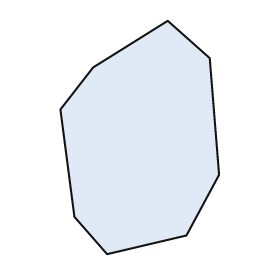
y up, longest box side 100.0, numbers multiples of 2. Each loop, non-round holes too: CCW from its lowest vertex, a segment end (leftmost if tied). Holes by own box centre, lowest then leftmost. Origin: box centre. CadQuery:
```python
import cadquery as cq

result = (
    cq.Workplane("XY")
    .moveTo(-14.0, -50.0)
    .lineTo(20.0, -42.0)
    .lineTo(34.0, -16.0)
    .lineTo(30.0, 34.0)
    .lineTo(12.0, 50.0)
    .lineTo(-20.0, 30.0)
    .lineTo(-34.0, 12.0)
    .lineTo(-28.0, -34.0)
    .close()
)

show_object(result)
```